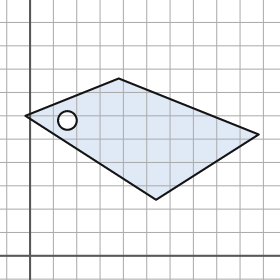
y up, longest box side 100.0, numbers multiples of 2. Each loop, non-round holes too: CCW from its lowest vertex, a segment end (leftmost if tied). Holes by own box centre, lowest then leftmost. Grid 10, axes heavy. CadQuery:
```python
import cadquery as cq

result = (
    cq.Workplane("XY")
    .moveTo(54.0, 24.0)
    .lineTo(98.0, 52.0)
    .lineTo(38.0, 76.0)
    .lineTo(-2.0, 60.0)
    .close()
    .moveTo(16.0, 58.0)
    .circle(4.0)
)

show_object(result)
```